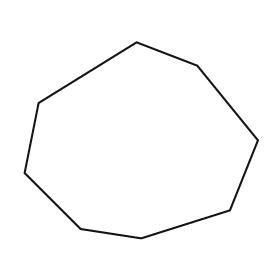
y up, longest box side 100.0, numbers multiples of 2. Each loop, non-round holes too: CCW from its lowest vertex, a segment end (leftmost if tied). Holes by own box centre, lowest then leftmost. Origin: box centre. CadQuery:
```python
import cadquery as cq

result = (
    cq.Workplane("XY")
    .moveTo(0.0, -42.0)
    .lineTo(38.0, -30.0)
    .lineTo(50.0, 0.0)
    .lineTo(24.0, 32.0)
    .lineTo(-2.0, 42.0)
    .lineTo(-44.0, 16.0)
    .lineTo(-50.0, -14.0)
    .lineTo(-26.0, -38.0)
    .close()
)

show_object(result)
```